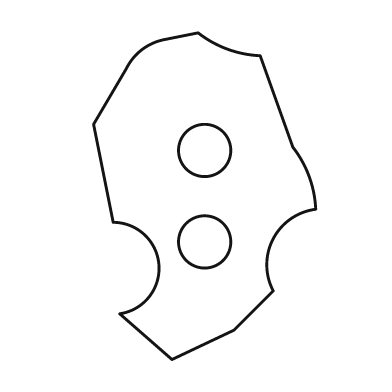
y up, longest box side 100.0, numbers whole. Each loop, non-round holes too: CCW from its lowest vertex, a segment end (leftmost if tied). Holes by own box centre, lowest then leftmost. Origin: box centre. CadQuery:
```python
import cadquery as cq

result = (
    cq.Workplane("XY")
    .moveTo(-10.0, -50.0)
    .lineTo(9.0, -41.0)
    .lineTo(21.0, -29.0)
    .threePointArc((21.0, -13.0), (34.0, -4.0))
    .threePointArc((32.0, 6.0), (27.0, 15.0))
    .lineTo(17.0, 43.0)
    .threePointArc((7.0, 45.0), (-2.0, 50.0))
    .lineTo(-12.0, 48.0)
    .threePointArc((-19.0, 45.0), (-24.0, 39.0))
    .lineTo(-34.0, 22.0)
    .lineTo(-28.0, -8.0)
    .threePointArc((-14.0, -21.0), (-26.0, -36.0))
    .close()
    .moveTo(0.0, -14.0)
    .circle(8.0)
    .moveTo(0.0, 14.0)
    .circle(8.0)
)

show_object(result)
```